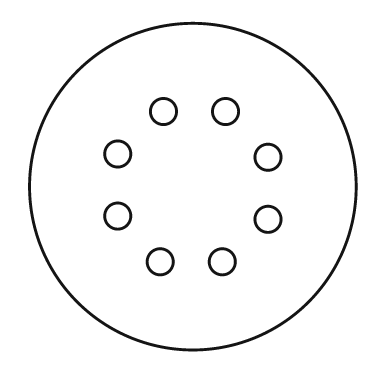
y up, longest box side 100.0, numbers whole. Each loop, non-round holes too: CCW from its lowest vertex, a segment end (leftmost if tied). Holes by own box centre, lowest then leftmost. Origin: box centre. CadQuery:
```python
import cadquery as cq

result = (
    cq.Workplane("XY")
    .moveTo(0.0, 0.0)
    .circle(50.0)
    .moveTo(-10.0, -23.0)
    .circle(4.0)
    .moveTo(9.0, -23.0)
    .circle(4.0)
    .moveTo(23.0, -10.0)
    .circle(4.0)
    .moveTo(-23.0, -9.0)
    .circle(4.0)
    .moveTo(23.0, 9.0)
    .circle(4.0)
    .moveTo(-23.0, 10.0)
    .circle(4.0)
    .moveTo(-9.0, 23.0)
    .circle(4.0)
    .moveTo(10.0, 23.0)
    .circle(4.0)
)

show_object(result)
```